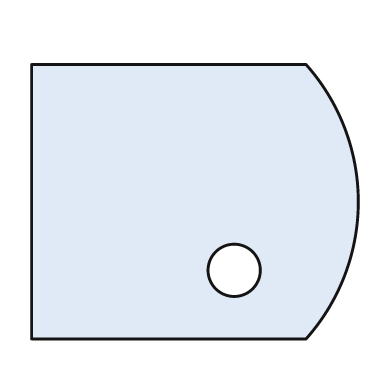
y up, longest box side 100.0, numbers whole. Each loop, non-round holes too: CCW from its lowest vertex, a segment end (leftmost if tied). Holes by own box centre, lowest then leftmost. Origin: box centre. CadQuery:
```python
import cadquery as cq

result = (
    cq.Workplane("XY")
    .moveTo(-50.0, -42.0)
    .lineTo(34.0, -42.0)
    .threePointArc((50.0, 0.0), (34.0, 42.0))
    .lineTo(-50.0, 42.0)
    .close()
    .moveTo(12.0, -21.0)
    .circle(8.0)
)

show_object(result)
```